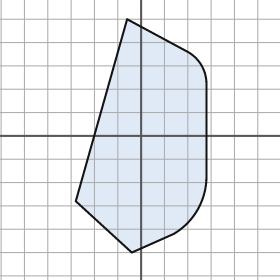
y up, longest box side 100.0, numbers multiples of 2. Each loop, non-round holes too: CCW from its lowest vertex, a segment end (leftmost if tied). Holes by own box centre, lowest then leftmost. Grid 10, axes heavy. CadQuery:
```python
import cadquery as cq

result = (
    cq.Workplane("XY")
    .moveTo(-4.0, -50.0)
    .lineTo(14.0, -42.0)
    .threePointArc((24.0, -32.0), (28.0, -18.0))
    .lineTo(28.0, 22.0)
    .threePointArc((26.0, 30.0), (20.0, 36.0))
    .lineTo(-6.0, 50.0)
    .lineTo(-28.0, -28.0)
    .close()
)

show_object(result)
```